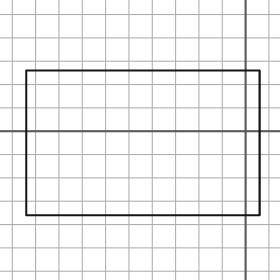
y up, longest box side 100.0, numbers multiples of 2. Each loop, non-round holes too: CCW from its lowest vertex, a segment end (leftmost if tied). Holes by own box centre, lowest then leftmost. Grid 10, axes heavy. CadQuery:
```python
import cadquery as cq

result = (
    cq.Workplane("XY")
    .moveTo(-94.0, -36.0)
    .lineTo(6.0, -36.0)
    .lineTo(6.0, 26.0)
    .lineTo(-94.0, 26.0)
    .close()
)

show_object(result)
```